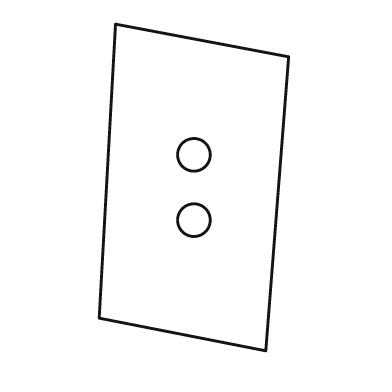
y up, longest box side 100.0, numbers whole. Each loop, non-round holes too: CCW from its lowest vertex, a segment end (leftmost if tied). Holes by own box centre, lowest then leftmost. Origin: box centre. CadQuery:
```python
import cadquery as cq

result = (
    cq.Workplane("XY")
    .moveTo(22.0, -50.0)
    .lineTo(29.0, 40.0)
    .lineTo(-24.0, 50.0)
    .lineTo(-29.0, -40.0)
    .close()
    .moveTo(0.0, -10.0)
    .circle(5.0)
    .moveTo(0.0, 10.0)
    .circle(5.0)
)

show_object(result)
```